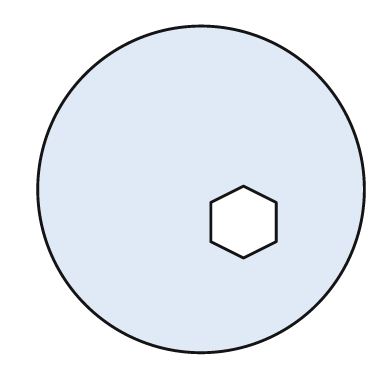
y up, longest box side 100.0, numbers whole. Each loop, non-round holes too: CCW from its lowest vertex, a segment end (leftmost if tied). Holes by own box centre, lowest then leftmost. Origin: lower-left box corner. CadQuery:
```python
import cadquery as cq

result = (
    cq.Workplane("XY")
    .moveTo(50.0, 50.0)
    .circle(50.0)
    .moveTo(63.0, 29.0)
    .lineTo(73.0, 34.0)
    .lineTo(73.0, 46.0)
    .lineTo(63.0, 51.0)
    .lineTo(53.0, 46.0)
    .lineTo(53.0, 34.0)
    .close()
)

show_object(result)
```